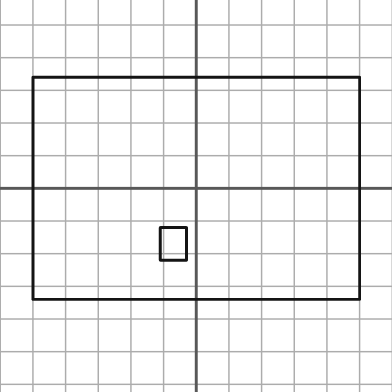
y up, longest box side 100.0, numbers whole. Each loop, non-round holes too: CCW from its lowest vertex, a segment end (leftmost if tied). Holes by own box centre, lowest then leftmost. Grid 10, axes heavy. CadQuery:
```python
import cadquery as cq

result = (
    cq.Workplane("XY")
    .moveTo(-50.0, -34.0)
    .lineTo(50.0, -34.0)
    .lineTo(50.0, 34.0)
    .lineTo(-50.0, 34.0)
    .close()
    .moveTo(-11.0, -22.0)
    .lineTo(-3.0, -22.0)
    .lineTo(-3.0, -12.0)
    .lineTo(-11.0, -12.0)
    .close()
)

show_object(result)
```